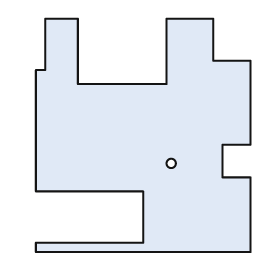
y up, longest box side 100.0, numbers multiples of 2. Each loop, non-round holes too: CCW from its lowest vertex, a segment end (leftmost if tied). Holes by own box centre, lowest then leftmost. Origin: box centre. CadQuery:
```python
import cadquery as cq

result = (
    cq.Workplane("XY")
    .moveTo(-46.0, -50.0)
    .lineTo(46.0, -50.0)
    .lineTo(46.0, -18.0)
    .lineTo(34.0, -18.0)
    .lineTo(34.0, -4.0)
    .lineTo(46.0, -4.0)
    .lineTo(46.0, 32.0)
    .lineTo(30.0, 32.0)
    .lineTo(30.0, 50.0)
    .lineTo(10.0, 50.0)
    .lineTo(10.0, 22.0)
    .lineTo(-28.0, 22.0)
    .lineTo(-28.0, 50.0)
    .lineTo(-42.0, 50.0)
    .lineTo(-42.0, 28.0)
    .lineTo(-46.0, 28.0)
    .lineTo(-46.0, -24.0)
    .lineTo(0.0, -24.0)
    .lineTo(0.0, -46.0)
    .lineTo(-46.0, -46.0)
    .close()
    .moveTo(12.0, -12.0)
    .circle(2.0)
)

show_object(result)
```